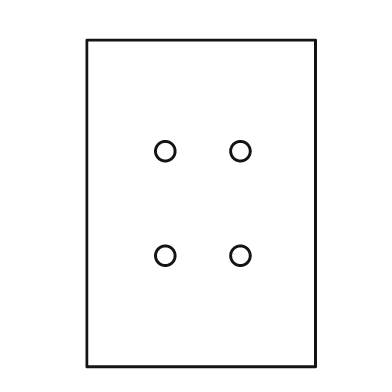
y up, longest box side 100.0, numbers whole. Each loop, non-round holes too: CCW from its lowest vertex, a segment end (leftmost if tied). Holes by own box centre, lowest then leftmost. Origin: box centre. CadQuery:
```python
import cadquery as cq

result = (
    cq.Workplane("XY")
    .moveTo(-35.0, -50.0)
    .lineTo(35.0, -50.0)
    .lineTo(35.0, 50.0)
    .lineTo(-35.0, 50.0)
    .close()
    .moveTo(-11.0, -16.0)
    .circle(3.0)
    .moveTo(12.0, -16.0)
    .circle(3.0)
    .moveTo(-11.0, 16.0)
    .circle(3.0)
    .moveTo(12.0, 16.0)
    .circle(3.0)
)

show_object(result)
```